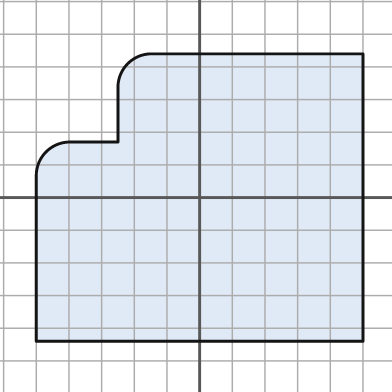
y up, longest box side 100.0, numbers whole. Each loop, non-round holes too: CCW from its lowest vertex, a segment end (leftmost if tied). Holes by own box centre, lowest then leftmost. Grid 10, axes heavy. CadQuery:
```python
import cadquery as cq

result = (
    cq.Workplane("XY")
    .moveTo(-50.0, -44.0)
    .lineTo(50.0, -44.0)
    .lineTo(50.0, 44.0)
    .lineTo(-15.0, 44.0)
    .threePointArc((-22.0, 41.0), (-25.0, 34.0))
    .lineTo(-25.0, 17.0)
    .lineTo(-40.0, 17.0)
    .threePointArc((-47.0, 14.0), (-50.0, 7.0))
    .close()
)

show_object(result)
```